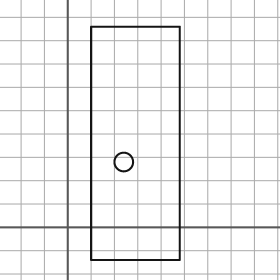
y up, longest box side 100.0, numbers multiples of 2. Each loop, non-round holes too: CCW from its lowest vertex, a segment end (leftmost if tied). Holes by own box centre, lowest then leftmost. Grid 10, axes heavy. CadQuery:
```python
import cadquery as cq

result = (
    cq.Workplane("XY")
    .moveTo(10.0, -14.0)
    .lineTo(48.0, -14.0)
    .lineTo(48.0, 86.0)
    .lineTo(10.0, 86.0)
    .close()
    .moveTo(24.0, 28.0)
    .circle(4.0)
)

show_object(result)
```